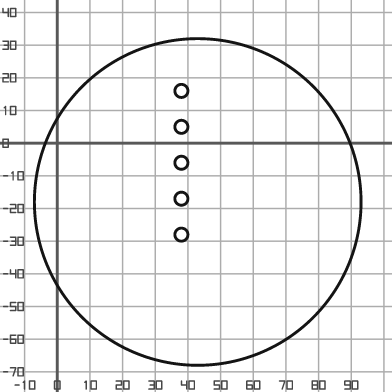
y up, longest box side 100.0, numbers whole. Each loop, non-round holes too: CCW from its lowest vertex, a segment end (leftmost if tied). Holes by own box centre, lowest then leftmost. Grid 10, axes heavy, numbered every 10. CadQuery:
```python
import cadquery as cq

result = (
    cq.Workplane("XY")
    .moveTo(43.0, -18.0)
    .circle(50.0)
    .moveTo(38.0, -28.0)
    .circle(2.0)
    .moveTo(38.0, -17.0)
    .circle(2.0)
    .moveTo(38.0, -6.0)
    .circle(2.0)
    .moveTo(38.0, 5.0)
    .circle(2.0)
    .moveTo(38.0, 16.0)
    .circle(2.0)
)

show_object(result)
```